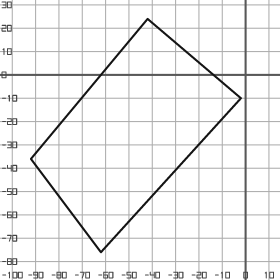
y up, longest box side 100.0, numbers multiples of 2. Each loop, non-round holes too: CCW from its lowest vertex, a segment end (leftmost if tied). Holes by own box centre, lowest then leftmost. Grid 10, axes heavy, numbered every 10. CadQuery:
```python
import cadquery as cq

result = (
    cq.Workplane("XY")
    .moveTo(-62.0, -76.0)
    .lineTo(-2.0, -10.0)
    .lineTo(-42.0, 24.0)
    .lineTo(-92.0, -36.0)
    .close()
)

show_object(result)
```